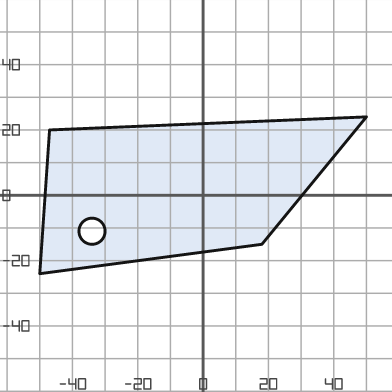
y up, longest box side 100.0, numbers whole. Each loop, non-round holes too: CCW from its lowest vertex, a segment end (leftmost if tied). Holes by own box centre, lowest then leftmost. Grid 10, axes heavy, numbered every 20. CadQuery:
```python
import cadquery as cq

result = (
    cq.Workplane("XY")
    .moveTo(-50.0, -24.0)
    .lineTo(18.0, -15.0)
    .lineTo(50.0, 24.0)
    .lineTo(-47.0, 20.0)
    .close()
    .moveTo(-34.0, -11.0)
    .circle(4.0)
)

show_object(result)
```